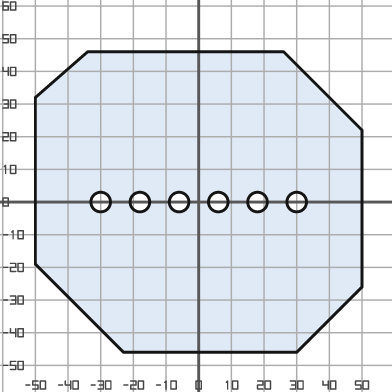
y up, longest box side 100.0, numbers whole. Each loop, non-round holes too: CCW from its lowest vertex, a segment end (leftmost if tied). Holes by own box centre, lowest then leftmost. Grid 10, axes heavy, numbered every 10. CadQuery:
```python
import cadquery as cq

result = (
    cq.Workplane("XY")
    .moveTo(-23.0, -46.0)
    .lineTo(30.0, -46.0)
    .lineTo(50.0, -26.0)
    .lineTo(50.0, 22.0)
    .lineTo(26.0, 46.0)
    .lineTo(-34.0, 46.0)
    .lineTo(-50.0, 32.0)
    .lineTo(-50.0, -19.0)
    .close()
    .moveTo(-30.0, 0.0)
    .circle(3.0)
    .moveTo(-18.0, 0.0)
    .circle(3.0)
    .moveTo(-6.0, 0.0)
    .circle(3.0)
    .moveTo(6.0, 0.0)
    .circle(3.0)
    .moveTo(18.0, 0.0)
    .circle(3.0)
    .moveTo(30.0, 0.0)
    .circle(3.0)
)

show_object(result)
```